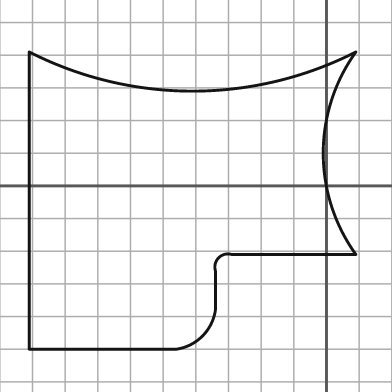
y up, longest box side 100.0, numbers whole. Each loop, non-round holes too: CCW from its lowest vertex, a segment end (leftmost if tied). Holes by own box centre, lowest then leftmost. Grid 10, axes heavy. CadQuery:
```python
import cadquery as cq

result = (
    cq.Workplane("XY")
    .moveTo(-91.0, -50.0)
    .lineTo(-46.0, -50.0)
    .threePointArc((-38.0, -46.0), (-34.0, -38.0))
    .lineTo(-34.0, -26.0)
    .threePointArc((-33.0, -22.0), (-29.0, -21.0))
    .lineTo(9.0, -21.0)
    .threePointArc((-1.0, 10.0), (9.0, 41.0))
    .threePointArc((-41.0, 29.0), (-91.0, 41.0))
    .close()
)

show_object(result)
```